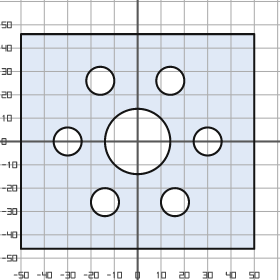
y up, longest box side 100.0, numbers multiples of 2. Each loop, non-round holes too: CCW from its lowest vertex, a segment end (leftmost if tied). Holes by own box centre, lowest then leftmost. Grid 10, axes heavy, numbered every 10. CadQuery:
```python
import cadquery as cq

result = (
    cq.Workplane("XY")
    .moveTo(-50.0, -46.0)
    .lineTo(50.0, -46.0)
    .lineTo(50.0, 46.0)
    .lineTo(-50.0, 46.0)
    .close()
    .moveTo(-14.0, -26.0)
    .circle(6.0)
    .moveTo(16.0, -26.0)
    .circle(6.0)
    .moveTo(-30.0, 0.0)
    .circle(6.0)
    .moveTo(0.0, 0.0)
    .circle(14.0)
    .moveTo(30.0, 0.0)
    .circle(6.0)
    .moveTo(-16.0, 26.0)
    .circle(6.0)
    .moveTo(14.0, 26.0)
    .circle(6.0)
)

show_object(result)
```